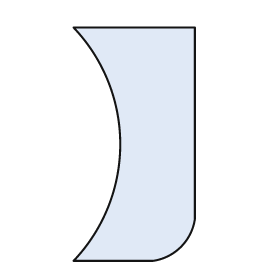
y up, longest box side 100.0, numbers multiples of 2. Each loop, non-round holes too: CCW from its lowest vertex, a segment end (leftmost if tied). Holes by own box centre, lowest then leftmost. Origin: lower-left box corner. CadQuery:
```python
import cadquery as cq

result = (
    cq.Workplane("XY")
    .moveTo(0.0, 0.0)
    .lineTo(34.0, 0.0)
    .threePointArc((46.0, 6.0), (52.0, 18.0))
    .lineTo(52.0, 100.0)
    .lineTo(0.0, 100.0)
    .threePointArc((20.0, 50.0), (0.0, 0.0))
    .close()
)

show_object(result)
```